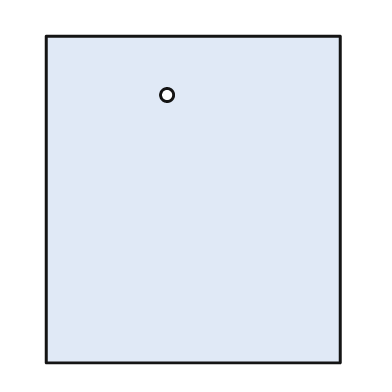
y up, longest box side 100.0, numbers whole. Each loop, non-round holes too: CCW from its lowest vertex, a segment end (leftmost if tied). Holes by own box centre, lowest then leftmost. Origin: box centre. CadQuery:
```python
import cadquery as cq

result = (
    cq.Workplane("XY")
    .moveTo(-45.0, -50.0)
    .lineTo(45.0, -50.0)
    .lineTo(45.0, 50.0)
    .lineTo(-45.0, 50.0)
    .close()
    .moveTo(-8.0, 32.0)
    .circle(2.0)
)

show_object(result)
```